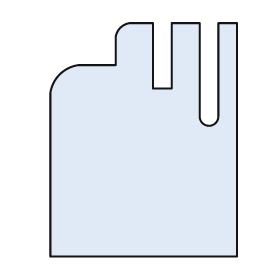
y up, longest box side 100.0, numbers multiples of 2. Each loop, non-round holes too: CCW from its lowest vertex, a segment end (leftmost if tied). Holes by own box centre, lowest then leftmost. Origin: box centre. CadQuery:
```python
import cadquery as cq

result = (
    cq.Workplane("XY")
    .moveTo(-40.0, -50.0)
    .lineTo(40.0, -50.0)
    .lineTo(40.0, 50.0)
    .lineTo(32.0, 50.0)
    .lineTo(32.0, 10.0)
    .threePointArc((28.0, 6.0), (24.0, 10.0))
    .lineTo(24.0, 50.0)
    .lineTo(12.0, 50.0)
    .lineTo(12.0, 22.0)
    .lineTo(4.0, 22.0)
    .lineTo(4.0, 50.0)
    .lineTo(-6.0, 50.0)
    .threePointArc((-10.0, 48.0), (-12.0, 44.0))
    .lineTo(-12.0, 32.0)
    .lineTo(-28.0, 32.0)
    .threePointArc((-36.0, 28.0), (-40.0, 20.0))
    .close()
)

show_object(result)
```